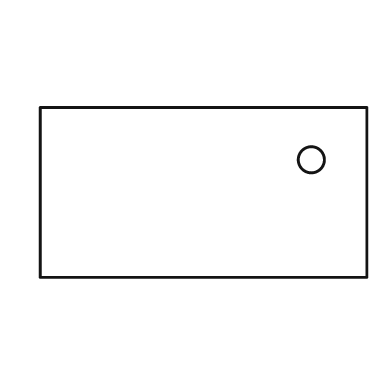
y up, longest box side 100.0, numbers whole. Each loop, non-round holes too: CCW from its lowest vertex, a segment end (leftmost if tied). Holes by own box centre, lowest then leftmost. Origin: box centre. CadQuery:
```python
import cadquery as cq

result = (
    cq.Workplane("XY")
    .moveTo(-50.0, -26.0)
    .lineTo(50.0, -26.0)
    .lineTo(50.0, 26.0)
    .lineTo(-50.0, 26.0)
    .close()
    .moveTo(33.0, 10.0)
    .circle(4.0)
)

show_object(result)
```